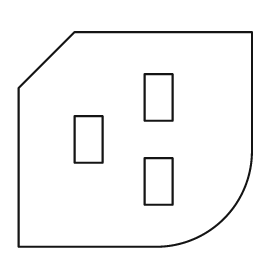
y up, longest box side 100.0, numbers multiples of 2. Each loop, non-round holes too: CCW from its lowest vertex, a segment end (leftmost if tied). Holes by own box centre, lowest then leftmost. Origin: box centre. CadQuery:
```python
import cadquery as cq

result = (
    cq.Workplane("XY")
    .moveTo(-50.0, -46.0)
    .lineTo(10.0, -46.0)
    .threePointArc((38.0, -34.0), (50.0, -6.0))
    .lineTo(50.0, 46.0)
    .lineTo(-26.0, 46.0)
    .lineTo(-50.0, 22.0)
    .close()
    .moveTo(4.0, -28.0)
    .lineTo(16.0, -28.0)
    .lineTo(16.0, -8.0)
    .lineTo(4.0, -8.0)
    .close()
    .moveTo(-26.0, -10.0)
    .lineTo(-14.0, -10.0)
    .lineTo(-14.0, 10.0)
    .lineTo(-26.0, 10.0)
    .close()
    .moveTo(4.0, 8.0)
    .lineTo(16.0, 8.0)
    .lineTo(16.0, 28.0)
    .lineTo(4.0, 28.0)
    .close()
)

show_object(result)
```